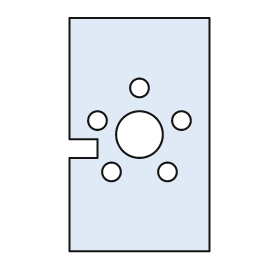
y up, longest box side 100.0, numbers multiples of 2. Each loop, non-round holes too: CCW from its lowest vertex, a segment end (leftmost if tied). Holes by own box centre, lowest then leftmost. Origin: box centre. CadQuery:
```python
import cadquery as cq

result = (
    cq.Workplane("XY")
    .moveTo(-30.0, -50.0)
    .lineTo(30.0, -50.0)
    .lineTo(30.0, 50.0)
    .lineTo(-30.0, 50.0)
    .lineTo(-30.0, -2.0)
    .lineTo(-18.0, -2.0)
    .lineTo(-18.0, -10.0)
    .lineTo(-30.0, -10.0)
    .close()
    .moveTo(-12.0, -16.0)
    .circle(4.0)
    .moveTo(12.0, -16.0)
    .circle(4.0)
    .moveTo(0.0, 0.0)
    .circle(10.0)
    .moveTo(-18.0, 6.0)
    .circle(4.0)
    .moveTo(18.0, 6.0)
    .circle(4.0)
    .moveTo(0.0, 20.0)
    .circle(4.0)
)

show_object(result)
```